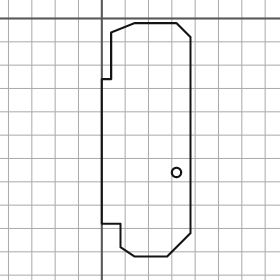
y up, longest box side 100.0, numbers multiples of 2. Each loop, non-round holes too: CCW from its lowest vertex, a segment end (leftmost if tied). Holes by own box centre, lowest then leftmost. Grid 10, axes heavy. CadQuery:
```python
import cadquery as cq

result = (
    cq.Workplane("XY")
    .moveTo(14.0, -102.0)
    .lineTo(28.0, -102.0)
    .lineTo(38.0, -92.0)
    .lineTo(38.0, -8.0)
    .lineTo(32.0, -2.0)
    .lineTo(14.0, -2.0)
    .lineTo(4.0, -6.0)
    .lineTo(4.0, -26.0)
    .lineTo(0.0, -26.0)
    .lineTo(0.0, -88.0)
    .lineTo(8.0, -88.0)
    .lineTo(8.0, -98.0)
    .close()
    .moveTo(32.0, -66.0)
    .circle(2.0)
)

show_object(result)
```